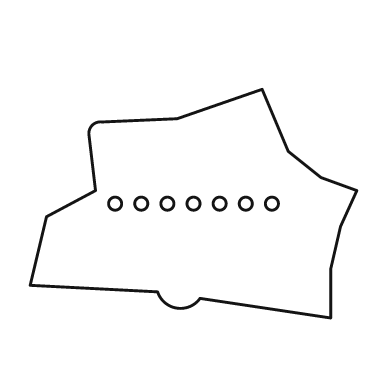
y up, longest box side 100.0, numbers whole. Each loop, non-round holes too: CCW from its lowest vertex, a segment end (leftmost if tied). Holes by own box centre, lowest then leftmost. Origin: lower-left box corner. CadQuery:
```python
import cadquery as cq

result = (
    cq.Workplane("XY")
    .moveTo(92.0, 0.0)
    .lineTo(92.0, 15.0)
    .lineTo(95.0, 28.0)
    .lineTo(100.0, 39.0)
    .lineTo(89.0, 43.0)
    .lineTo(79.0, 51.0)
    .lineTo(71.0, 70.0)
    .lineTo(45.0, 61.0)
    .lineTo(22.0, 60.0)
    .threePointArc((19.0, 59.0), (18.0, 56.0))
    .lineTo(20.0, 39.0)
    .lineTo(5.0, 31.0)
    .lineTo(0.0, 10.0)
    .lineTo(39.0, 8.0)
    .threePointArc((45.0, 3.0), (52.0, 6.0))
    .close()
    .moveTo(26.0, 35.0)
    .circle(2.0)
    .moveTo(34.0, 35.0)
    .circle(2.0)
    .moveTo(42.0, 35.0)
    .circle(2.0)
    .moveTo(50.0, 35.0)
    .circle(2.0)
    .moveTo(58.0, 35.0)
    .circle(2.0)
    .moveTo(66.0, 35.0)
    .circle(2.0)
    .moveTo(74.0, 35.0)
    .circle(2.0)
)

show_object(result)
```